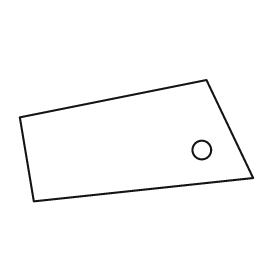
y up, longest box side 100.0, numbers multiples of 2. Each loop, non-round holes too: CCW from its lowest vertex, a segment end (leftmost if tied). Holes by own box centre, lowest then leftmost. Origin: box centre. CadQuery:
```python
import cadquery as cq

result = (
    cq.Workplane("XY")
    .moveTo(-44.0, -26.0)
    .lineTo(50.0, -16.0)
    .lineTo(30.0, 26.0)
    .lineTo(-50.0, 10.0)
    .close()
    .moveTo(28.0, -4.0)
    .circle(4.0)
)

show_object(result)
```